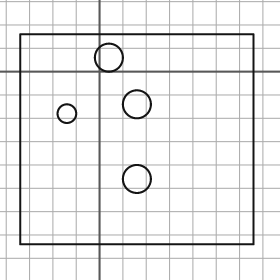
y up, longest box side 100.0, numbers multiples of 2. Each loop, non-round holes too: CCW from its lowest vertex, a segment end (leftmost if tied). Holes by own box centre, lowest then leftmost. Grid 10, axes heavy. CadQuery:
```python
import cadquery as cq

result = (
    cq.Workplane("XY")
    .moveTo(-34.0, -74.0)
    .lineTo(66.0, -74.0)
    .lineTo(66.0, 16.0)
    .lineTo(-34.0, 16.0)
    .close()
    .moveTo(16.0, -46.0)
    .circle(6.0)
    .moveTo(-14.0, -18.0)
    .circle(4.0)
    .moveTo(16.0, -14.0)
    .circle(6.0)
    .moveTo(4.0, 6.0)
    .circle(6.0)
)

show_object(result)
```